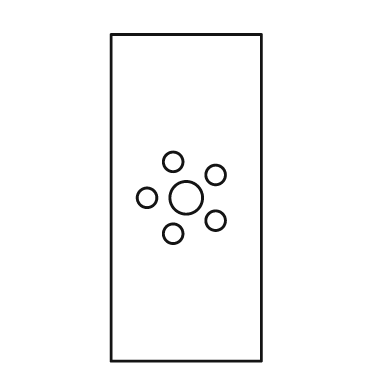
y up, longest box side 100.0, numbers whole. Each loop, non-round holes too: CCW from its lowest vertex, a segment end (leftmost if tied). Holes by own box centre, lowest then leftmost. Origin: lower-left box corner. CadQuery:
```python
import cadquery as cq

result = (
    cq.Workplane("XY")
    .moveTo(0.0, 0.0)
    .lineTo(46.0, 0.0)
    .lineTo(46.0, 100.0)
    .lineTo(0.0, 100.0)
    .close()
    .moveTo(19.0, 39.0)
    .circle(3.0)
    .moveTo(32.0, 43.0)
    .circle(3.0)
    .moveTo(11.0, 50.0)
    .circle(3.0)
    .moveTo(23.0, 50.0)
    .circle(5.0)
    .moveTo(32.0, 57.0)
    .circle(3.0)
    .moveTo(19.0, 61.0)
    .circle(3.0)
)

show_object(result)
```